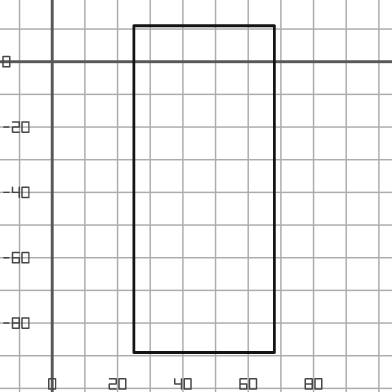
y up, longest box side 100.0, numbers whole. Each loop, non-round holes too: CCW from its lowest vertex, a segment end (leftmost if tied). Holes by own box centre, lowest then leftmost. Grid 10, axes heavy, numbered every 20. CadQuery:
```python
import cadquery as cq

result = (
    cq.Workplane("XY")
    .moveTo(25.0, -89.0)
    .lineTo(68.0, -89.0)
    .lineTo(68.0, 11.0)
    .lineTo(25.0, 11.0)
    .close()
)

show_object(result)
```